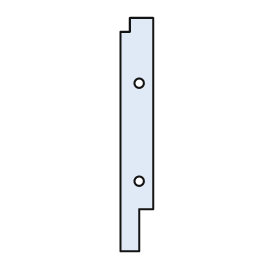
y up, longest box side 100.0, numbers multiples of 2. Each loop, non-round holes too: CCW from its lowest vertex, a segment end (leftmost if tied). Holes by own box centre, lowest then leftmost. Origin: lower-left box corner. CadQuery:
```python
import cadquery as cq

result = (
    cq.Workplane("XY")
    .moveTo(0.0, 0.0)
    .lineTo(8.0, 0.0)
    .lineTo(8.0, 18.0)
    .lineTo(14.0, 18.0)
    .lineTo(14.0, 100.0)
    .lineTo(4.0, 100.0)
    .lineTo(4.0, 94.0)
    .lineTo(0.0, 94.0)
    .close()
    .moveTo(8.0, 30.0)
    .circle(2.0)
    .moveTo(8.0, 72.0)
    .circle(2.0)
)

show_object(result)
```